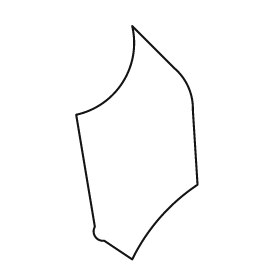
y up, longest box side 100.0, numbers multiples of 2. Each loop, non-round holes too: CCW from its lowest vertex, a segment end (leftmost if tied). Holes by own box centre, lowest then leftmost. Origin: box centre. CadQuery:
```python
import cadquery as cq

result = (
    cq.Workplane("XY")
    .moveTo(-2.0, -50.0)
    .threePointArc((10.0, -32.0), (26.0, -18.0))
    .lineTo(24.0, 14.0)
    .threePointArc((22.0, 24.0), (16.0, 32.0))
    .lineTo(-2.0, 50.0)
    .threePointArc((-6.0, 26.0), (-26.0, 12.0))
    .lineTo(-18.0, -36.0)
    .threePointArc((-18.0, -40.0), (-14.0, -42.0))
    .close()
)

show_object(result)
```